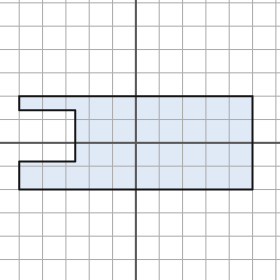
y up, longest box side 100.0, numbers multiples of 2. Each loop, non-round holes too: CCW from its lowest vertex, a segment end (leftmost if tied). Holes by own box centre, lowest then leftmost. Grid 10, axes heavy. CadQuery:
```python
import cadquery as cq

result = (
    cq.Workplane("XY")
    .moveTo(-50.0, -20.0)
    .lineTo(50.0, -20.0)
    .lineTo(50.0, 20.0)
    .lineTo(-50.0, 20.0)
    .lineTo(-50.0, 14.0)
    .lineTo(-26.0, 14.0)
    .lineTo(-26.0, -8.0)
    .lineTo(-50.0, -8.0)
    .close()
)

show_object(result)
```